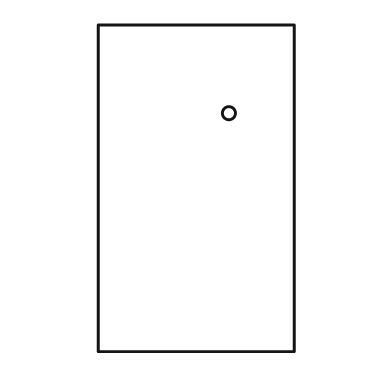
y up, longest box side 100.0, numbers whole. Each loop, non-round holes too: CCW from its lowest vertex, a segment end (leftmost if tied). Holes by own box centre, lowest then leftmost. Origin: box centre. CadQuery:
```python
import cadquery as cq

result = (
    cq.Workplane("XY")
    .moveTo(-30.0, -50.0)
    .lineTo(30.0, -50.0)
    .lineTo(30.0, 50.0)
    .lineTo(-30.0, 50.0)
    .close()
    .moveTo(10.0, 23.0)
    .circle(2.0)
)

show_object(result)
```